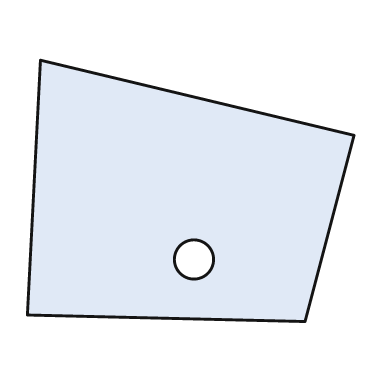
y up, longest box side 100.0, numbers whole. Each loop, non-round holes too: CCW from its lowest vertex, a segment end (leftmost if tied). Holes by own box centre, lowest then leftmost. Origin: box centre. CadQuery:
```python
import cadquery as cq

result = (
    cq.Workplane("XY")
    .moveTo(35.0, -40.0)
    .lineTo(50.0, 17.0)
    .lineTo(-46.0, 40.0)
    .lineTo(-50.0, -38.0)
    .close()
    .moveTo(1.0, -21.0)
    .circle(6.0)
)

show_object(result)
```